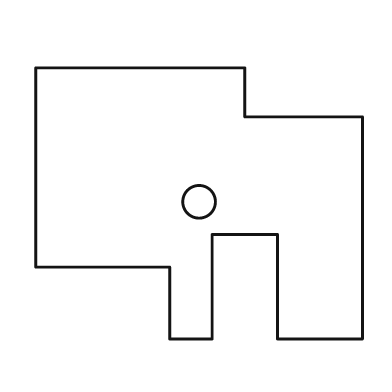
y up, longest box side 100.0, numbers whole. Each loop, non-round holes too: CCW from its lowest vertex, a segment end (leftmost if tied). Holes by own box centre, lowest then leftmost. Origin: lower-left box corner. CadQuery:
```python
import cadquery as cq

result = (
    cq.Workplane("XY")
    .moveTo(41.0, 0.0)
    .lineTo(54.0, 0.0)
    .lineTo(54.0, 32.0)
    .lineTo(74.0, 32.0)
    .lineTo(74.0, 0.0)
    .lineTo(100.0, 0.0)
    .lineTo(100.0, 68.0)
    .lineTo(64.0, 68.0)
    .lineTo(64.0, 83.0)
    .lineTo(0.0, 83.0)
    .lineTo(0.0, 22.0)
    .lineTo(41.0, 22.0)
    .close()
    .moveTo(50.0, 42.0)
    .circle(5.0)
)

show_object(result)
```